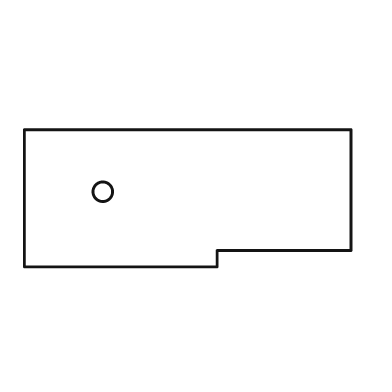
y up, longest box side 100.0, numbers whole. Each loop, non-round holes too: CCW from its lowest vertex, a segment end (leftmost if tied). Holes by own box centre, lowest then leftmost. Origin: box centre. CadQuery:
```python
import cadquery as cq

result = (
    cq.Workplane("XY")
    .moveTo(-50.0, -21.0)
    .lineTo(9.0, -21.0)
    .lineTo(9.0, -16.0)
    .lineTo(50.0, -16.0)
    .lineTo(50.0, 21.0)
    .lineTo(-50.0, 21.0)
    .close()
    .moveTo(-26.0, 2.0)
    .circle(3.0)
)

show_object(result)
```